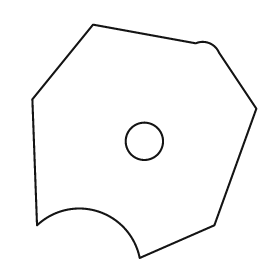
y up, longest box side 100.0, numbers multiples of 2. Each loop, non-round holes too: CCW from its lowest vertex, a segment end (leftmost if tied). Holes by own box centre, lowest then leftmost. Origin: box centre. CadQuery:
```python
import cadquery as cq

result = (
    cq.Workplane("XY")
    .moveTo(-2.0, -50.0)
    .lineTo(30.0, -36.0)
    .lineTo(48.0, 14.0)
    .lineTo(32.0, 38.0)
    .threePointArc((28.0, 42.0), (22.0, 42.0))
    .lineTo(-22.0, 50.0)
    .lineTo(-48.0, 18.0)
    .lineTo(-46.0, -36.0)
    .threePointArc((-20.0, -30.0), (-2.0, -50.0))
    .close()
    .moveTo(0.0, 0.0)
    .circle(8.0)
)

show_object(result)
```